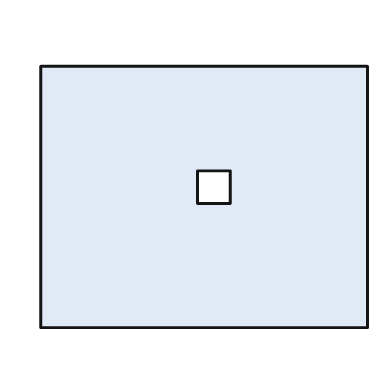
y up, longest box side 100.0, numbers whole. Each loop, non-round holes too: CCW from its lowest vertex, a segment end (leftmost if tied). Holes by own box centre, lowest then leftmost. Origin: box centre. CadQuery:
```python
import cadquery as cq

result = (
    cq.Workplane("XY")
    .moveTo(-50.0, -40.0)
    .lineTo(50.0, -40.0)
    .lineTo(50.0, 40.0)
    .lineTo(-50.0, 40.0)
    .close()
    .moveTo(-2.0, -2.0)
    .lineTo(8.0, -2.0)
    .lineTo(8.0, 8.0)
    .lineTo(-2.0, 8.0)
    .close()
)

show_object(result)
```